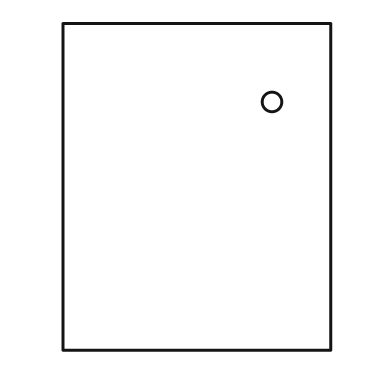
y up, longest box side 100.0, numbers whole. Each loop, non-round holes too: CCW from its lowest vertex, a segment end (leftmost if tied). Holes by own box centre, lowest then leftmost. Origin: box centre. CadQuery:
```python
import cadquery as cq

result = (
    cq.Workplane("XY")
    .moveTo(-41.0, -50.0)
    .lineTo(41.0, -50.0)
    .lineTo(41.0, 50.0)
    .lineTo(-41.0, 50.0)
    .close()
    .moveTo(23.0, 26.0)
    .circle(3.0)
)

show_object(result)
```